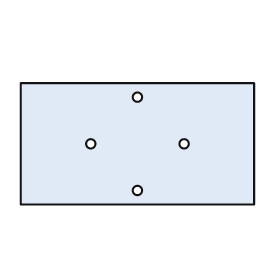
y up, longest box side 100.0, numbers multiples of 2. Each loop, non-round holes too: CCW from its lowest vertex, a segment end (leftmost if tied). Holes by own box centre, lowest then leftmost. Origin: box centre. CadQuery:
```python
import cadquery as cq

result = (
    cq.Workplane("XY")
    .moveTo(-50.0, -26.0)
    .lineTo(50.0, -26.0)
    .lineTo(50.0, 26.0)
    .lineTo(-50.0, 26.0)
    .close()
    .moveTo(0.0, -20.0)
    .circle(2.0)
    .moveTo(-20.0, 0.0)
    .circle(2.0)
    .moveTo(20.0, 0.0)
    .circle(2.0)
    .moveTo(0.0, 20.0)
    .circle(2.0)
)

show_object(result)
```